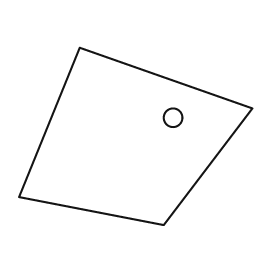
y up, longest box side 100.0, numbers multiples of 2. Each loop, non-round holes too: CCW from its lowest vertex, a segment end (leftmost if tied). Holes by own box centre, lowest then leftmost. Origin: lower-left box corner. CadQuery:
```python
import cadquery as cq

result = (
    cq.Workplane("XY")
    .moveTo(62.0, 0.0)
    .lineTo(100.0, 50.0)
    .lineTo(26.0, 76.0)
    .lineTo(0.0, 12.0)
    .close()
    .moveTo(66.0, 46.0)
    .circle(4.0)
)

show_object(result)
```